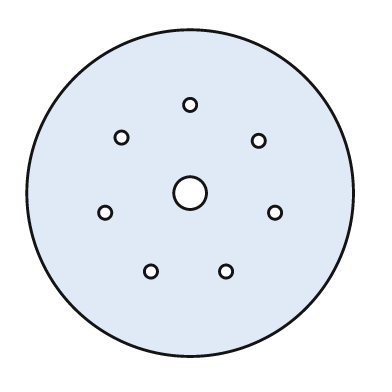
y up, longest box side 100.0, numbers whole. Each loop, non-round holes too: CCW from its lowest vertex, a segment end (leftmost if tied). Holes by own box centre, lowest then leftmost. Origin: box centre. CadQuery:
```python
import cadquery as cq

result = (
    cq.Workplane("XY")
    .moveTo(0.0, 0.0)
    .circle(50.0)
    .moveTo(-12.0, -24.0)
    .circle(2.0)
    .moveTo(11.0, -24.0)
    .circle(2.0)
    .moveTo(-26.0, -6.0)
    .circle(2.0)
    .moveTo(26.0, -6.0)
    .circle(2.0)
    .moveTo(0.0, 0.0)
    .circle(5.0)
    .moveTo(21.0, 16.0)
    .circle(2.0)
    .moveTo(-21.0, 17.0)
    .circle(2.0)
    .moveTo(0.0, 27.0)
    .circle(2.0)
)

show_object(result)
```